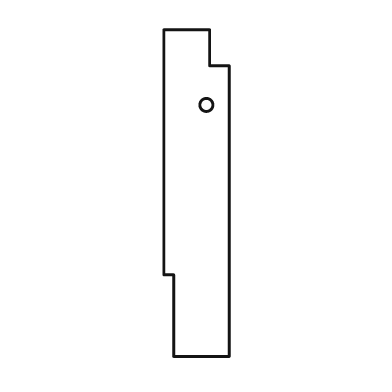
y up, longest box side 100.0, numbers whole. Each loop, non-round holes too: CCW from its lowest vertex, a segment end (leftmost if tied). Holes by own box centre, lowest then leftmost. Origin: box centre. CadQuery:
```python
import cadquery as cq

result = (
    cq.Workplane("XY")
    .moveTo(-7.0, -50.0)
    .lineTo(10.0, -50.0)
    .lineTo(10.0, 39.0)
    .lineTo(4.0, 39.0)
    .lineTo(4.0, 50.0)
    .lineTo(-10.0, 50.0)
    .lineTo(-10.0, -25.0)
    .lineTo(-7.0, -25.0)
    .close()
    .moveTo(3.0, 27.0)
    .circle(2.0)
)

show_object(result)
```